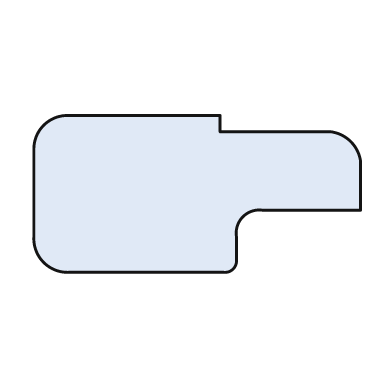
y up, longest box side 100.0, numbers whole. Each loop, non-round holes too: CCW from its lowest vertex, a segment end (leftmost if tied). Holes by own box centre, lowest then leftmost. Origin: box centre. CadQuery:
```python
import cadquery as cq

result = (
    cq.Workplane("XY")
    .moveTo(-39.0, -24.0)
    .lineTo(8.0, -24.0)
    .threePointArc((11.0, -23.0), (12.0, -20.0))
    .lineTo(12.0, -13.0)
    .threePointArc((14.0, -7.0), (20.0, -5.0))
    .lineTo(50.0, -5.0)
    .lineTo(50.0, 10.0)
    .threePointArc((47.0, 16.0), (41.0, 19.0))
    .lineTo(7.0, 19.0)
    .lineTo(7.0, 24.0)
    .lineTo(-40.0, 24.0)
    .threePointArc((-47.0, 21.0), (-50.0, 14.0))
    .lineTo(-50.0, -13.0)
    .threePointArc((-47.0, -21.0), (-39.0, -24.0))
    .close()
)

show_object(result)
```